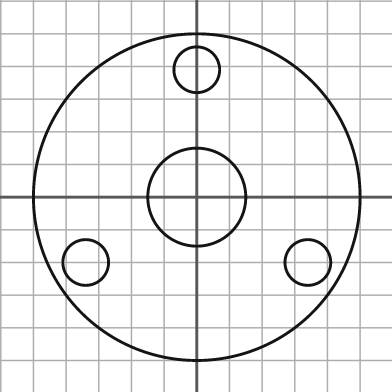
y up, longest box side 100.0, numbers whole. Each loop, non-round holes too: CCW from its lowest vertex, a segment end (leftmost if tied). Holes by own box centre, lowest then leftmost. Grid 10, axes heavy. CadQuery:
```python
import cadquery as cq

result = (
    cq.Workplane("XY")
    .moveTo(0.0, 0.0)
    .circle(50.0)
    .moveTo(-34.0, -20.0)
    .circle(7.0)
    .moveTo(34.0, -20.0)
    .circle(7.0)
    .moveTo(0.0, 0.0)
    .circle(15.0)
    .moveTo(0.0, 39.0)
    .circle(7.0)
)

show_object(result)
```